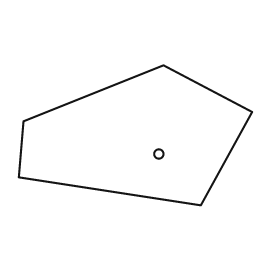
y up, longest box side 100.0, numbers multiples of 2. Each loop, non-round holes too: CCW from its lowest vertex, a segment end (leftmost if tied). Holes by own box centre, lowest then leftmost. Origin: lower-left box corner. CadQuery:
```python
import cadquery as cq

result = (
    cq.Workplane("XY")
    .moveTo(78.0, 0.0)
    .lineTo(100.0, 40.0)
    .lineTo(62.0, 60.0)
    .lineTo(2.0, 36.0)
    .lineTo(0.0, 12.0)
    .close()
    .moveTo(60.0, 22.0)
    .circle(2.0)
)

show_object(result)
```